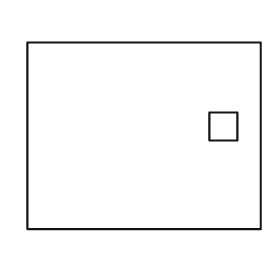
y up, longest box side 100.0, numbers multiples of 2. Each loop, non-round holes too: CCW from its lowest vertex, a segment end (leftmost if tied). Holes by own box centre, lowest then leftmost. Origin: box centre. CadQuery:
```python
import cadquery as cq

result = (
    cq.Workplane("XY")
    .moveTo(-50.0, -40.0)
    .lineTo(50.0, -40.0)
    .lineTo(50.0, 40.0)
    .lineTo(-50.0, 40.0)
    .close()
    .moveTo(28.0, -2.0)
    .lineTo(40.0, -2.0)
    .lineTo(40.0, 10.0)
    .lineTo(28.0, 10.0)
    .close()
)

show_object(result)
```